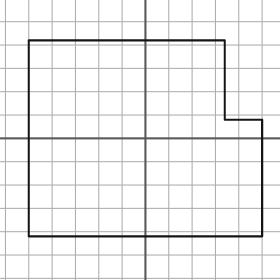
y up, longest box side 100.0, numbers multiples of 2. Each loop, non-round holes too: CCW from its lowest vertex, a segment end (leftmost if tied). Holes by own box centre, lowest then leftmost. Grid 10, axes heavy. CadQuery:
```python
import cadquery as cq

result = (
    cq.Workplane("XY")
    .moveTo(-50.0, -42.0)
    .lineTo(50.0, -42.0)
    .lineTo(50.0, 8.0)
    .lineTo(34.0, 8.0)
    .lineTo(34.0, 42.0)
    .lineTo(-50.0, 42.0)
    .close()
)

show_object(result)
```